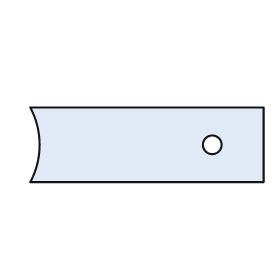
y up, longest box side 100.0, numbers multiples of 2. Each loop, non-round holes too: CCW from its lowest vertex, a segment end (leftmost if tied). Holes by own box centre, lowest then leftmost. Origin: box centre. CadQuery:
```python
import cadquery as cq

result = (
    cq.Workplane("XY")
    .moveTo(-50.0, -16.0)
    .lineTo(50.0, -16.0)
    .lineTo(50.0, 16.0)
    .lineTo(-50.0, 16.0)
    .threePointArc((-46.0, 0.0), (-50.0, -16.0))
    .close()
    .moveTo(28.0, 0.0)
    .circle(4.0)
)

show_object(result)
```